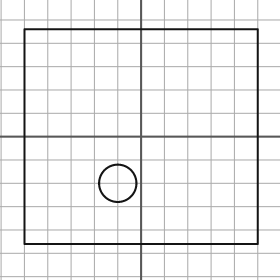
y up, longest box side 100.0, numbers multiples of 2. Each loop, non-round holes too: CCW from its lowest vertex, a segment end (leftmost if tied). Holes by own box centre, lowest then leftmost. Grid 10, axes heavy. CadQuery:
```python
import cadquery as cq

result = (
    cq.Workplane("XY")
    .moveTo(-50.0, -46.0)
    .lineTo(50.0, -46.0)
    .lineTo(50.0, 46.0)
    .lineTo(-50.0, 46.0)
    .close()
    .moveTo(-10.0, -20.0)
    .circle(8.0)
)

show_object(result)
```